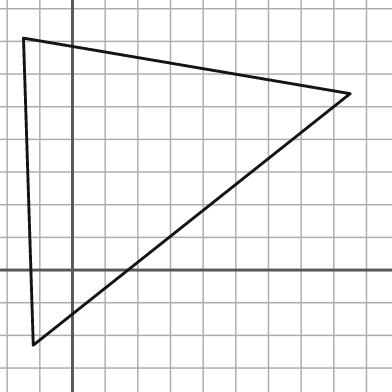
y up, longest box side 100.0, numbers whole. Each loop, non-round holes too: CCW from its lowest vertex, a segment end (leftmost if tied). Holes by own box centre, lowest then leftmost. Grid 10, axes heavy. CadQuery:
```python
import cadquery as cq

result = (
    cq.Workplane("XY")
    .moveTo(-12.0, -23.0)
    .lineTo(85.0, 54.0)
    .lineTo(-15.0, 71.0)
    .close()
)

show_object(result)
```